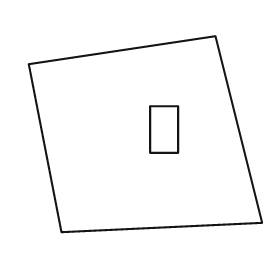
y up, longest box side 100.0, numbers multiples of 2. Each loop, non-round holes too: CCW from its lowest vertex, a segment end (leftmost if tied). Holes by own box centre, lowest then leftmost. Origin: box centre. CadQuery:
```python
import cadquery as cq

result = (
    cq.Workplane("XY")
    .moveTo(-36.0, -42.0)
    .lineTo(50.0, -38.0)
    .lineTo(30.0, 42.0)
    .lineTo(-50.0, 30.0)
    .close()
    .moveTo(2.0, -8.0)
    .lineTo(14.0, -8.0)
    .lineTo(14.0, 12.0)
    .lineTo(2.0, 12.0)
    .close()
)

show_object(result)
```